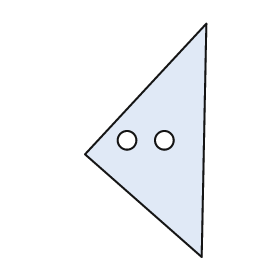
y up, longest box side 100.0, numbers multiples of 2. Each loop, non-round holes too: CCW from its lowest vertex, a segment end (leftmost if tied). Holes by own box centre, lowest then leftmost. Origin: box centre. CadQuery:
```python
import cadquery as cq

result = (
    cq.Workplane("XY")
    .moveTo(24.0, -50.0)
    .lineTo(26.0, 50.0)
    .lineTo(-26.0, -6.0)
    .close()
    .moveTo(-8.0, 0.0)
    .circle(4.0)
    .moveTo(8.0, 0.0)
    .circle(4.0)
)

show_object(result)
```